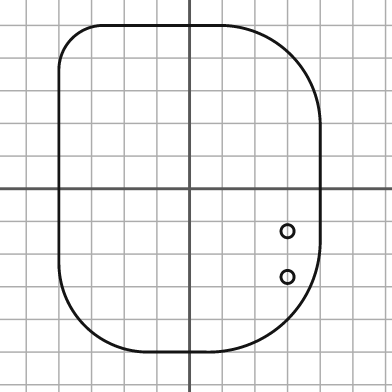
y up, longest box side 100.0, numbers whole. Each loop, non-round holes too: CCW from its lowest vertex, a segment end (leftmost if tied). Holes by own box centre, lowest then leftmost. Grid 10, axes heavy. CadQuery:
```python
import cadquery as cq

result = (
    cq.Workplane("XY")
    .moveTo(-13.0, -50.0)
    .lineTo(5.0, -50.0)
    .threePointArc((30.0, -40.0), (40.0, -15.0))
    .lineTo(40.0, 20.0)
    .threePointArc((31.0, 41.0), (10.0, 50.0))
    .lineTo(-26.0, 50.0)
    .threePointArc((-36.0, 46.0), (-40.0, 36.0))
    .lineTo(-40.0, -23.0)
    .threePointArc((-32.0, -42.0), (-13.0, -50.0))
    .close()
    .moveTo(30.0, -27.0)
    .circle(2.0)
    .moveTo(30.0, -13.0)
    .circle(2.0)
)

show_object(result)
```